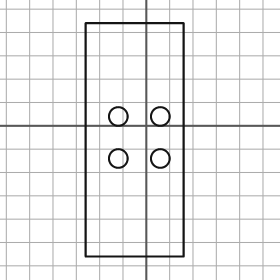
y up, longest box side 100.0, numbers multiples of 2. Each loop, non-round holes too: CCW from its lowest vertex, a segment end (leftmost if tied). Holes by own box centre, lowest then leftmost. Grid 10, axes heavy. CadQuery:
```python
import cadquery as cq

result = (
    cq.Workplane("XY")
    .moveTo(-26.0, -56.0)
    .lineTo(16.0, -56.0)
    .lineTo(16.0, 44.0)
    .lineTo(-26.0, 44.0)
    .close()
    .moveTo(-12.0, -14.0)
    .circle(4.0)
    .moveTo(6.0, -14.0)
    .circle(4.0)
    .moveTo(-12.0, 4.0)
    .circle(4.0)
    .moveTo(6.0, 4.0)
    .circle(4.0)
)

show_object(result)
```